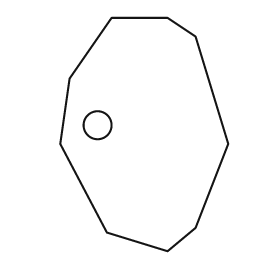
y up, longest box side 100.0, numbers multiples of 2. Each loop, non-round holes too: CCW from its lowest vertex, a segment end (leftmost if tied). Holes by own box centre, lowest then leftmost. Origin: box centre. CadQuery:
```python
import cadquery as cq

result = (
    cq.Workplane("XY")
    .moveTo(10.0, -50.0)
    .lineTo(22.0, -40.0)
    .lineTo(36.0, -4.0)
    .lineTo(22.0, 42.0)
    .lineTo(10.0, 50.0)
    .lineTo(-14.0, 50.0)
    .lineTo(-32.0, 24.0)
    .lineTo(-36.0, -4.0)
    .lineTo(-16.0, -42.0)
    .close()
    .moveTo(-20.0, 4.0)
    .circle(6.0)
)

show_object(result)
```